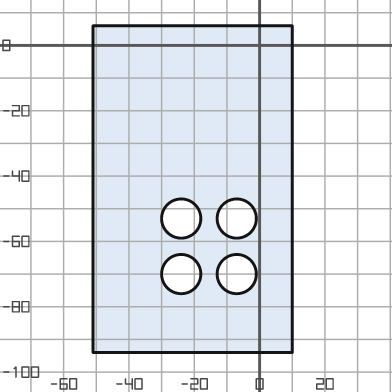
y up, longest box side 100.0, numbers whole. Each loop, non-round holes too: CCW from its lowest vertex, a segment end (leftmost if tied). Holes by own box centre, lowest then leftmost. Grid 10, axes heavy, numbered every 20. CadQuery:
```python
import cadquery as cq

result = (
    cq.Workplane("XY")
    .moveTo(-51.0, -94.0)
    .lineTo(10.0, -94.0)
    .lineTo(10.0, 6.0)
    .lineTo(-51.0, 6.0)
    .close()
    .moveTo(-24.0, -70.0)
    .circle(6.0)
    .moveTo(-7.0, -70.0)
    .circle(6.0)
    .moveTo(-24.0, -53.0)
    .circle(6.0)
    .moveTo(-7.0, -53.0)
    .circle(6.0)
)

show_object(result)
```